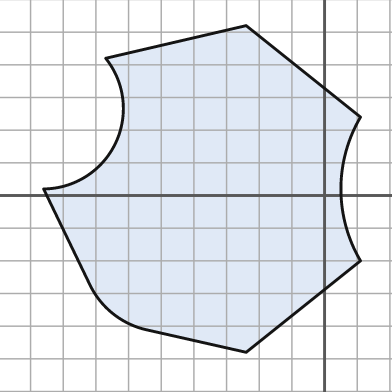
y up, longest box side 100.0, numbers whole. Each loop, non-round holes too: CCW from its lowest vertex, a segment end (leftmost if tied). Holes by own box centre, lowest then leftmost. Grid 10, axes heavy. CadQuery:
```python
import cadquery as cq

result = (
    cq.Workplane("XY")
    .moveTo(-24.0, -48.0)
    .lineTo(11.0, -20.0)
    .threePointArc((5.0, 2.0), (11.0, 24.0))
    .lineTo(-24.0, 52.0)
    .lineTo(-67.0, 42.0)
    .threePointArc((-64.0, 16.0), (-86.0, 2.0))
    .lineTo(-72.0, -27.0)
    .threePointArc((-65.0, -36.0), (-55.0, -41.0))
    .close()
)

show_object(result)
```